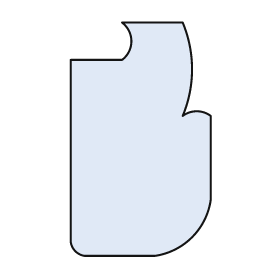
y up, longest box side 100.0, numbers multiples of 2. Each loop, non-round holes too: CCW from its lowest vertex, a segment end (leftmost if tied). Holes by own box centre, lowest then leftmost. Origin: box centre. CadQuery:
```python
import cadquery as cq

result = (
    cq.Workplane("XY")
    .moveTo(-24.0, -50.0)
    .lineTo(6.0, -50.0)
    .threePointArc((22.0, -42.0), (30.0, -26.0))
    .lineTo(30.0, 10.0)
    .threePointArc((24.0, 12.0), (18.0, 10.0))
    .threePointArc((22.0, 30.0), (18.0, 50.0))
    .lineTo(-8.0, 50.0)
    .threePointArc((-4.0, 42.0), (-8.0, 34.0))
    .lineTo(-30.0, 34.0)
    .lineTo(-30.0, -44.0)
    .threePointArc((-28.0, -48.0), (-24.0, -50.0))
    .close()
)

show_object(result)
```